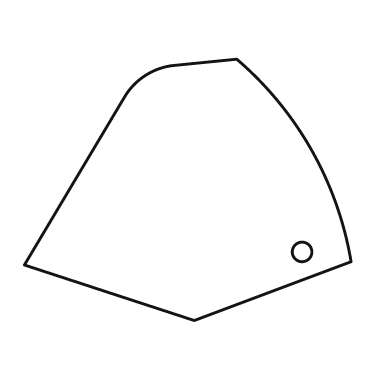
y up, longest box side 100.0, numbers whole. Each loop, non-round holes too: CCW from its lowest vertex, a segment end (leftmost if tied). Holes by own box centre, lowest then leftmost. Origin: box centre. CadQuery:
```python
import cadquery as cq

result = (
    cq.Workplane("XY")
    .moveTo(2.0, -40.0)
    .lineTo(50.0, -22.0)
    .threePointArc((38.0, 12.0), (15.0, 40.0))
    .lineTo(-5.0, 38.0)
    .threePointArc((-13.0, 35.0), (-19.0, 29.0))
    .lineTo(-50.0, -23.0)
    .close()
    .moveTo(35.0, -19.0)
    .circle(3.0)
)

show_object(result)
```